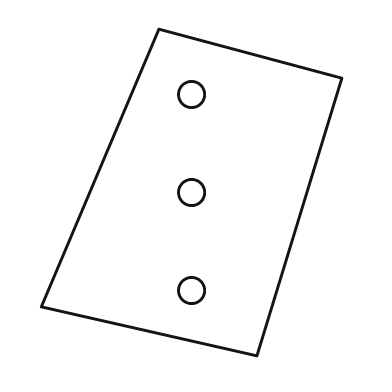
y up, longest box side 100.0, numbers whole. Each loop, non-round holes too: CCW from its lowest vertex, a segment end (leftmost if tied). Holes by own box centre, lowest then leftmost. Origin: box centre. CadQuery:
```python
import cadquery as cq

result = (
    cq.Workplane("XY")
    .moveTo(20.0, -50.0)
    .lineTo(46.0, 35.0)
    .lineTo(-10.0, 50.0)
    .lineTo(-46.0, -35.0)
    .close()
    .moveTo(0.0, -30.0)
    .circle(4.0)
    .moveTo(0.0, 0.0)
    .circle(4.0)
    .moveTo(0.0, 30.0)
    .circle(4.0)
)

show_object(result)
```